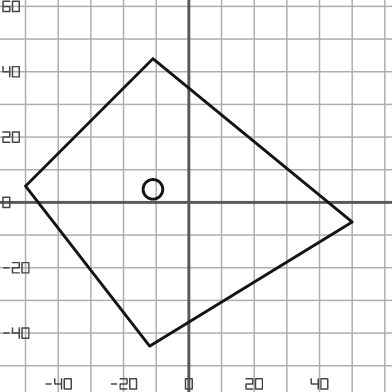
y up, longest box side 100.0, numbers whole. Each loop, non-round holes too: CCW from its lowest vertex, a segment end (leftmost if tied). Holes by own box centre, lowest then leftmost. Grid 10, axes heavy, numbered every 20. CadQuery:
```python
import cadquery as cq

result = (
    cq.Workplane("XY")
    .moveTo(-12.0, -44.0)
    .lineTo(50.0, -6.0)
    .lineTo(-11.0, 44.0)
    .lineTo(-50.0, 5.0)
    .close()
    .moveTo(-11.0, 4.0)
    .circle(3.0)
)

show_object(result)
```